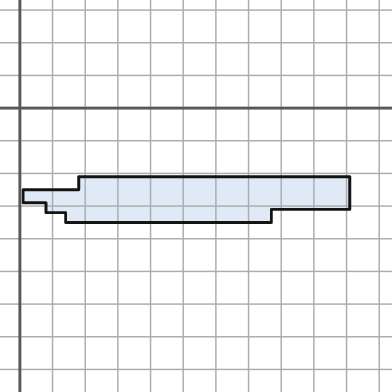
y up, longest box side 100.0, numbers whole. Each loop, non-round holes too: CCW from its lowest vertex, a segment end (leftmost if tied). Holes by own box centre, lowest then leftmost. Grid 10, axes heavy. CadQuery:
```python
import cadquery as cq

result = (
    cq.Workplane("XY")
    .moveTo(14.0, -35.0)
    .lineTo(77.0, -35.0)
    .lineTo(77.0, -31.0)
    .lineTo(101.0, -31.0)
    .lineTo(101.0, -21.0)
    .lineTo(18.0, -21.0)
    .lineTo(18.0, -25.0)
    .lineTo(1.0, -25.0)
    .lineTo(1.0, -29.0)
    .lineTo(8.0, -29.0)
    .lineTo(8.0, -32.0)
    .lineTo(14.0, -32.0)
    .close()
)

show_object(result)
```